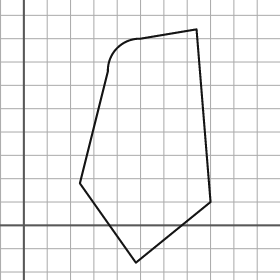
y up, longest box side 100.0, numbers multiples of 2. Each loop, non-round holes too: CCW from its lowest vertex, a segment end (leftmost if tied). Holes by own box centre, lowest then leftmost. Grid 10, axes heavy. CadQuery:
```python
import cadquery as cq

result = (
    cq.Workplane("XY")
    .moveTo(48.0, -16.0)
    .lineTo(80.0, 10.0)
    .lineTo(74.0, 84.0)
    .lineTo(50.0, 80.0)
    .threePointArc((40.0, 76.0), (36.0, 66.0))
    .lineTo(24.0, 18.0)
    .close()
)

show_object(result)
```